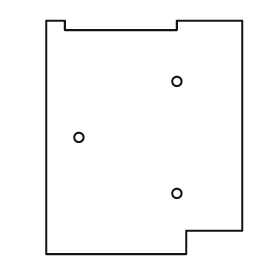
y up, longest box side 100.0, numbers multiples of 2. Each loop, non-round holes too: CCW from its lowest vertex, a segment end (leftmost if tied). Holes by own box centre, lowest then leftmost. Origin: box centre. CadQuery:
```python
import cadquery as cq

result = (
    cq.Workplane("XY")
    .moveTo(-42.0, -50.0)
    .lineTo(18.0, -50.0)
    .lineTo(18.0, -40.0)
    .lineTo(42.0, -40.0)
    .lineTo(42.0, 50.0)
    .lineTo(14.0, 50.0)
    .lineTo(14.0, 46.0)
    .lineTo(-34.0, 46.0)
    .lineTo(-34.0, 50.0)
    .lineTo(-42.0, 50.0)
    .close()
    .moveTo(14.0, -24.0)
    .circle(2.0)
    .moveTo(-28.0, 0.0)
    .circle(2.0)
    .moveTo(14.0, 24.0)
    .circle(2.0)
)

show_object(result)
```